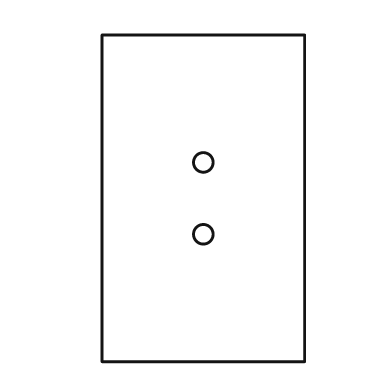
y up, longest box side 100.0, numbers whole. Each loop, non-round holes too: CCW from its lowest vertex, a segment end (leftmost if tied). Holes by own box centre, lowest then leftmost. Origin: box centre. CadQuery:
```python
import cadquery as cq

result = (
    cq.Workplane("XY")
    .moveTo(-31.0, -50.0)
    .lineTo(31.0, -50.0)
    .lineTo(31.0, 50.0)
    .lineTo(-31.0, 50.0)
    .close()
    .moveTo(0.0, -11.0)
    .circle(3.0)
    .moveTo(0.0, 11.0)
    .circle(3.0)
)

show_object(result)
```